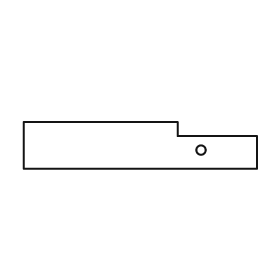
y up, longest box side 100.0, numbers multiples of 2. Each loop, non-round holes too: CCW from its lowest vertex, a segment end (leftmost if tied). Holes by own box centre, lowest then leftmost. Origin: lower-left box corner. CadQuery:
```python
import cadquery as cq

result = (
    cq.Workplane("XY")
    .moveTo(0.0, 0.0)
    .lineTo(100.0, 0.0)
    .lineTo(100.0, 14.0)
    .lineTo(66.0, 14.0)
    .lineTo(66.0, 20.0)
    .lineTo(0.0, 20.0)
    .close()
    .moveTo(76.0, 8.0)
    .circle(2.0)
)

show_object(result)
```